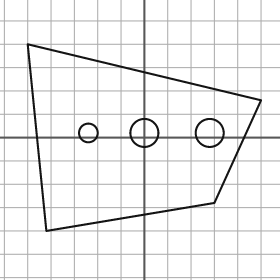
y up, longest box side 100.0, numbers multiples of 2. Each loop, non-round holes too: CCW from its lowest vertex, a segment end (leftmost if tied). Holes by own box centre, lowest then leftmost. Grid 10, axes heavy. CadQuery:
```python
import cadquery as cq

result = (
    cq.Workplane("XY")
    .moveTo(-42.0, -40.0)
    .lineTo(30.0, -28.0)
    .lineTo(50.0, 16.0)
    .lineTo(-50.0, 40.0)
    .close()
    .moveTo(-24.0, 2.0)
    .circle(4.0)
    .moveTo(0.0, 2.0)
    .circle(6.0)
    .moveTo(28.0, 2.0)
    .circle(6.0)
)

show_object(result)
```